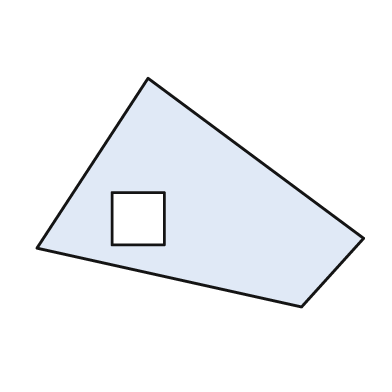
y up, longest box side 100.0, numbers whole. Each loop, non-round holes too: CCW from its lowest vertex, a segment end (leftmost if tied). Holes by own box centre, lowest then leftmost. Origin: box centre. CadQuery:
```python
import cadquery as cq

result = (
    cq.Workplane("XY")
    .moveTo(31.0, -35.0)
    .lineTo(50.0, -14.0)
    .lineTo(-16.0, 35.0)
    .lineTo(-50.0, -17.0)
    .close()
    .moveTo(-27.0, -16.0)
    .lineTo(-11.0, -16.0)
    .lineTo(-11.0, 0.0)
    .lineTo(-27.0, 0.0)
    .close()
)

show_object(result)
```